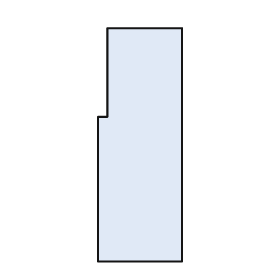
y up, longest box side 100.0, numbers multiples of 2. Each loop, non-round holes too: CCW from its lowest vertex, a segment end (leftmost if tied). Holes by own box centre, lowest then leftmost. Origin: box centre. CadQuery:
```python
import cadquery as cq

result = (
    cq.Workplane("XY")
    .moveTo(-18.0, -50.0)
    .lineTo(18.0, -50.0)
    .lineTo(18.0, 50.0)
    .lineTo(-14.0, 50.0)
    .lineTo(-14.0, 12.0)
    .lineTo(-18.0, 12.0)
    .close()
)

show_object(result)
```